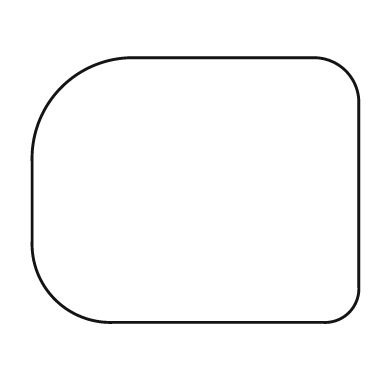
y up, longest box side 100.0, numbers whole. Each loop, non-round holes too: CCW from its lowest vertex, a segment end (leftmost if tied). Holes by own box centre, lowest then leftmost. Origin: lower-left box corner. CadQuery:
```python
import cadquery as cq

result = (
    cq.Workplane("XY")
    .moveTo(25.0, 0.0)
    .lineTo(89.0, 0.0)
    .threePointArc((97.0, 3.0), (100.0, 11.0))
    .lineTo(100.0, 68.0)
    .threePointArc((96.0, 77.0), (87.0, 81.0))
    .lineTo(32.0, 81.0)
    .threePointArc((9.0, 72.0), (0.0, 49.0))
    .lineTo(0.0, 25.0)
    .threePointArc((7.0, 7.0), (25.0, 0.0))
    .close()
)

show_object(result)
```